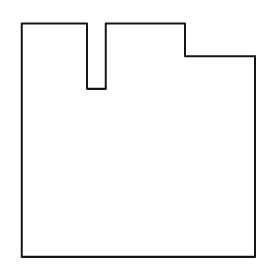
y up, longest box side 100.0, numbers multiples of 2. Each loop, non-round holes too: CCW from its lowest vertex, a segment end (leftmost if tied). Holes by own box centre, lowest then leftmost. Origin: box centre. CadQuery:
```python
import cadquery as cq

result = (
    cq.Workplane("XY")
    .moveTo(-50.0, -50.0)
    .lineTo(50.0, -50.0)
    .lineTo(50.0, 36.0)
    .lineTo(20.0, 36.0)
    .lineTo(20.0, 50.0)
    .lineTo(-14.0, 50.0)
    .lineTo(-14.0, 22.0)
    .lineTo(-22.0, 22.0)
    .lineTo(-22.0, 50.0)
    .lineTo(-50.0, 50.0)
    .close()
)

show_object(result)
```